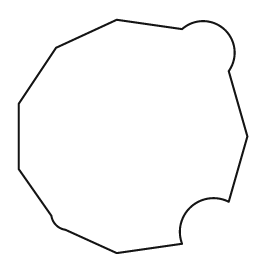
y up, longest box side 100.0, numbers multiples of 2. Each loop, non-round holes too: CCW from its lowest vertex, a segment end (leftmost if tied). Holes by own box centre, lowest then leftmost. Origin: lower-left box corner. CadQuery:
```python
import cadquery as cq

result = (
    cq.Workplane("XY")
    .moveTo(42.0, 0.0)
    .lineTo(70.0, 4.0)
    .threePointArc((74.0, 20.0), (90.0, 22.0))
    .lineTo(98.0, 50.0)
    .lineTo(90.0, 78.0)
    .threePointArc((88.0, 96.0), (70.0, 96.0))
    .lineTo(42.0, 100.0)
    .lineTo(16.0, 88.0)
    .lineTo(0.0, 64.0)
    .lineTo(0.0, 36.0)
    .lineTo(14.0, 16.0)
    .threePointArc((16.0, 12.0), (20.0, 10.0))
    .close()
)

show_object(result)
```